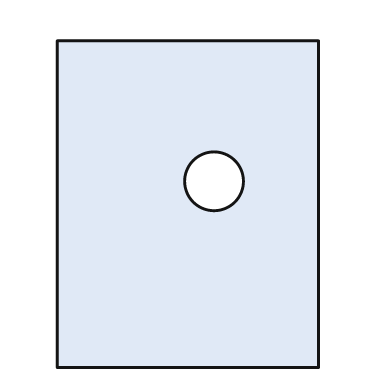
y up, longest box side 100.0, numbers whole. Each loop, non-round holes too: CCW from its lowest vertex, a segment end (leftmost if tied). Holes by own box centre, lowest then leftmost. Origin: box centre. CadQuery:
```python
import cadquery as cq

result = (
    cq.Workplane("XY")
    .moveTo(-40.0, -50.0)
    .lineTo(40.0, -50.0)
    .lineTo(40.0, 50.0)
    .lineTo(-40.0, 50.0)
    .close()
    .moveTo(8.0, 7.0)
    .circle(9.0)
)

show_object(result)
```